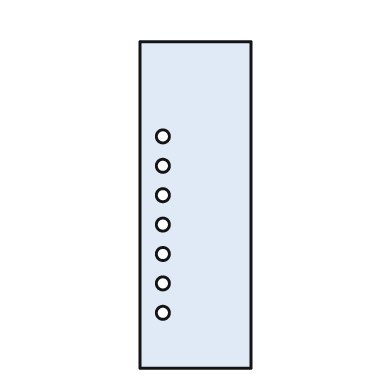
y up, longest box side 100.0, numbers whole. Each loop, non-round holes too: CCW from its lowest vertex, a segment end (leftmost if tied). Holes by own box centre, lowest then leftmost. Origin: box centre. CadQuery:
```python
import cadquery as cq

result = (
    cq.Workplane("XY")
    .moveTo(-17.0, -50.0)
    .lineTo(17.0, -50.0)
    .lineTo(17.0, 50.0)
    .lineTo(-17.0, 50.0)
    .close()
    .moveTo(-10.0, -33.0)
    .circle(2.0)
    .moveTo(-10.0, -24.0)
    .circle(2.0)
    .moveTo(-10.0, -15.0)
    .circle(2.0)
    .moveTo(-10.0, -6.0)
    .circle(2.0)
    .moveTo(-10.0, 3.0)
    .circle(2.0)
    .moveTo(-10.0, 12.0)
    .circle(2.0)
    .moveTo(-10.0, 21.0)
    .circle(2.0)
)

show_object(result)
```